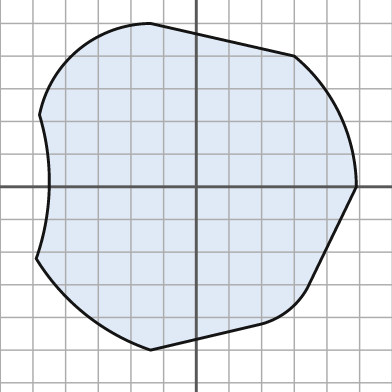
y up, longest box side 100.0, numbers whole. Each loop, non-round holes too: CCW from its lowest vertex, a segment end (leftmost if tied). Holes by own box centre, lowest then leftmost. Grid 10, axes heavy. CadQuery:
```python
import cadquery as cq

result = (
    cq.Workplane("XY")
    .moveTo(-14.0, -50.0)
    .lineTo(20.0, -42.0)
    .threePointArc((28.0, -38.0), (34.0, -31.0))
    .lineTo(49.0, 0.0)
    .threePointArc((44.0, 22.0), (30.0, 40.0))
    .lineTo(-14.0, 50.0)
    .threePointArc((-36.0, 42.0), (-48.0, 22.0))
    .threePointArc((-45.0, 0.0), (-49.0, -22.0))
    .threePointArc((-34.0, -39.0), (-14.0, -50.0))
    .close()
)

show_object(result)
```